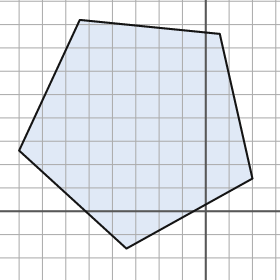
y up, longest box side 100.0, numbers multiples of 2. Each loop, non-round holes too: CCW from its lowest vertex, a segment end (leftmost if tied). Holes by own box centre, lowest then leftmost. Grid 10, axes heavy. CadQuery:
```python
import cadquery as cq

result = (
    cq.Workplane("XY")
    .moveTo(-34.0, -16.0)
    .lineTo(20.0, 14.0)
    .lineTo(6.0, 76.0)
    .lineTo(-54.0, 82.0)
    .lineTo(-80.0, 26.0)
    .close()
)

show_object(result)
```